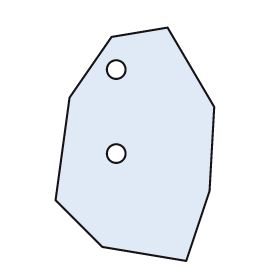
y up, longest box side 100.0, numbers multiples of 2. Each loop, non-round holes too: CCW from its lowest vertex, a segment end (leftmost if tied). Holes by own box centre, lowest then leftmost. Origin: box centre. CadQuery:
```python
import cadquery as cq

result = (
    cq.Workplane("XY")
    .moveTo(22.0, -50.0)
    .lineTo(32.0, -20.0)
    .lineTo(34.0, 16.0)
    .lineTo(14.0, 50.0)
    .lineTo(-10.0, 46.0)
    .lineTo(-28.0, 20.0)
    .lineTo(-34.0, -24.0)
    .lineTo(-14.0, -44.0)
    .close()
    .moveTo(-8.0, -4.0)
    .circle(4.0)
    .moveTo(-8.0, 32.0)
    .circle(4.0)
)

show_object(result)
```